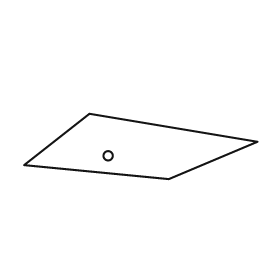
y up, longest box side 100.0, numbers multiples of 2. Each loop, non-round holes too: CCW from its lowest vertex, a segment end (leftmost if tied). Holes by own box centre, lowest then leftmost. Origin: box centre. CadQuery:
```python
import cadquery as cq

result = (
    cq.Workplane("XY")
    .moveTo(12.0, -14.0)
    .lineTo(50.0, 2.0)
    .lineTo(-22.0, 14.0)
    .lineTo(-50.0, -8.0)
    .close()
    .moveTo(-14.0, -4.0)
    .circle(2.0)
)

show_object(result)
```